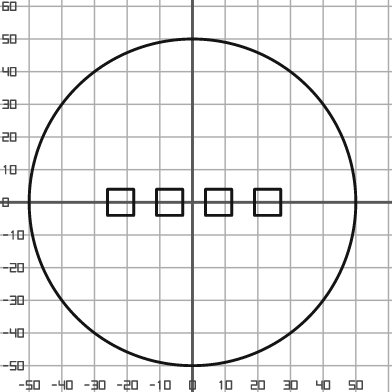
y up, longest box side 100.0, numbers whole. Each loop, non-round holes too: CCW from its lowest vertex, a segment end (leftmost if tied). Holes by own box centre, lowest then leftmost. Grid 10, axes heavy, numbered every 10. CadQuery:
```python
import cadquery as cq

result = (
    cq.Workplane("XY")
    .moveTo(0.0, 0.0)
    .circle(50.0)
    .moveTo(-26.0, -4.0)
    .lineTo(-18.0, -4.0)
    .lineTo(-18.0, 4.0)
    .lineTo(-26.0, 4.0)
    .close()
    .moveTo(-11.0, -4.0)
    .lineTo(-3.0, -4.0)
    .lineTo(-3.0, 4.0)
    .lineTo(-11.0, 4.0)
    .close()
    .moveTo(4.0, -4.0)
    .lineTo(12.0, -4.0)
    .lineTo(12.0, 4.0)
    .lineTo(4.0, 4.0)
    .close()
    .moveTo(19.0, -4.0)
    .lineTo(27.0, -4.0)
    .lineTo(27.0, 4.0)
    .lineTo(19.0, 4.0)
    .close()
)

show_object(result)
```